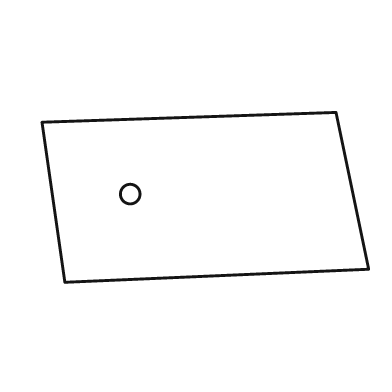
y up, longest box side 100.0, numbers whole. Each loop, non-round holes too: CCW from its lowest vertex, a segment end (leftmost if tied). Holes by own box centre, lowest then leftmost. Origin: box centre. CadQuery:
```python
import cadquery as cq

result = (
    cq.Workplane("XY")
    .moveTo(-43.0, -26.0)
    .lineTo(50.0, -22.0)
    .lineTo(40.0, 26.0)
    .lineTo(-50.0, 23.0)
    .close()
    .moveTo(-23.0, 1.0)
    .circle(3.0)
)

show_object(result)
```